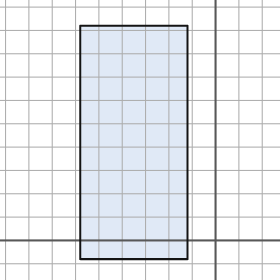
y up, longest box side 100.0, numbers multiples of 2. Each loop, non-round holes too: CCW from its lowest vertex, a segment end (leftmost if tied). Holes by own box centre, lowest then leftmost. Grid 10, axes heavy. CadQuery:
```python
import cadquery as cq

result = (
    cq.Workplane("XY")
    .moveTo(-58.0, -8.0)
    .lineTo(-12.0, -8.0)
    .lineTo(-12.0, 92.0)
    .lineTo(-58.0, 92.0)
    .close()
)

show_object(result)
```